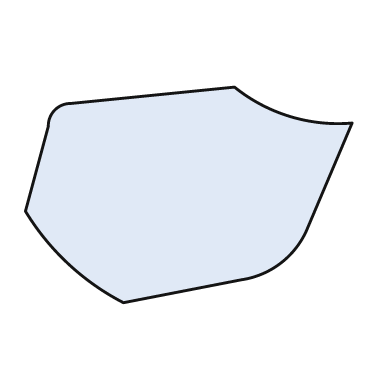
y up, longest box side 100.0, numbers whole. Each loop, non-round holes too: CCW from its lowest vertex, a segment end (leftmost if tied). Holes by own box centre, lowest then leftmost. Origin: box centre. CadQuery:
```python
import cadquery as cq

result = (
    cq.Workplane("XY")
    .moveTo(-20.0, -33.0)
    .lineTo(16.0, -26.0)
    .threePointArc((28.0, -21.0), (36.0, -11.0))
    .lineTo(50.0, 22.0)
    .threePointArc((31.0, 24.0), (14.0, 33.0))
    .lineTo(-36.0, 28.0)
    .threePointArc((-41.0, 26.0), (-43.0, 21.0))
    .lineTo(-50.0, -5.0)
    .threePointArc((-37.0, -21.0), (-20.0, -33.0))
    .close()
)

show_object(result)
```